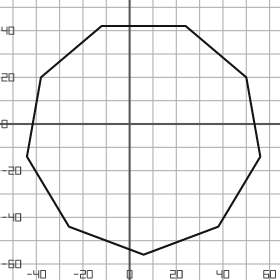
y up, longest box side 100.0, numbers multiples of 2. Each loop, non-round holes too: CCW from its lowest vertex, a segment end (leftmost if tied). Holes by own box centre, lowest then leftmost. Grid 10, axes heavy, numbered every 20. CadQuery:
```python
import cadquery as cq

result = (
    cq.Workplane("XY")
    .moveTo(6.0, -56.0)
    .lineTo(38.0, -44.0)
    .lineTo(56.0, -14.0)
    .lineTo(50.0, 20.0)
    .lineTo(24.0, 42.0)
    .lineTo(-12.0, 42.0)
    .lineTo(-38.0, 20.0)
    .lineTo(-44.0, -14.0)
    .lineTo(-26.0, -44.0)
    .close()
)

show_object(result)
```